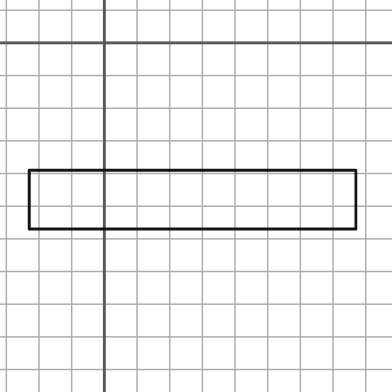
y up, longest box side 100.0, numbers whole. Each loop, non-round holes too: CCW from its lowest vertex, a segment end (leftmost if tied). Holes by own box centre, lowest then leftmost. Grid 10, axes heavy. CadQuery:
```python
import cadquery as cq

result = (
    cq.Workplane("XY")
    .moveTo(-23.0, -57.0)
    .lineTo(77.0, -57.0)
    .lineTo(77.0, -39.0)
    .lineTo(-23.0, -39.0)
    .close()
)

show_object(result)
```